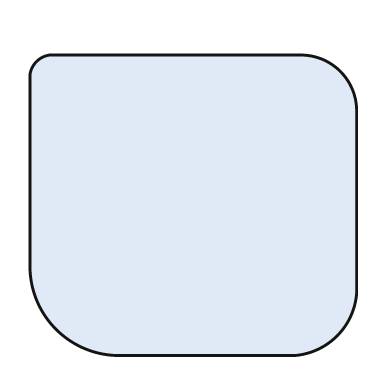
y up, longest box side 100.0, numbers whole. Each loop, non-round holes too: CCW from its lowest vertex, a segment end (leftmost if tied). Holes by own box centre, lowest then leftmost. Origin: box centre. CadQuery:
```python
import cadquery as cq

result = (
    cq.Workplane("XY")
    .moveTo(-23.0, -46.0)
    .lineTo(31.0, -46.0)
    .threePointArc((44.0, -40.0), (50.0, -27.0))
    .lineTo(50.0, 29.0)
    .threePointArc((45.0, 41.0), (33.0, 46.0))
    .lineTo(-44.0, 46.0)
    .threePointArc((-48.0, 44.0), (-50.0, 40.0))
    .lineTo(-50.0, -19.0)
    .threePointArc((-42.0, -38.0), (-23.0, -46.0))
    .close()
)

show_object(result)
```